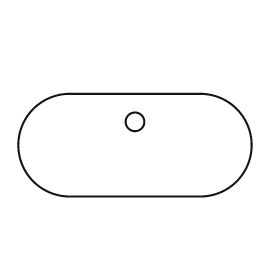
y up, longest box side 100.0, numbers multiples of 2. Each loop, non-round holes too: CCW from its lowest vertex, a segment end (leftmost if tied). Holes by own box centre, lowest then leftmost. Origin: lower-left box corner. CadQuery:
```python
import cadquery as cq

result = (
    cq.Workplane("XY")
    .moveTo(22.0, 0.0)
    .lineTo(78.0, 0.0)
    .threePointArc((100.0, 22.0), (78.0, 44.0))
    .lineTo(22.0, 44.0)
    .threePointArc((0.0, 22.0), (22.0, 0.0))
    .close()
    .moveTo(50.0, 32.0)
    .circle(4.0)
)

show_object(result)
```